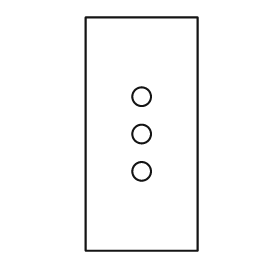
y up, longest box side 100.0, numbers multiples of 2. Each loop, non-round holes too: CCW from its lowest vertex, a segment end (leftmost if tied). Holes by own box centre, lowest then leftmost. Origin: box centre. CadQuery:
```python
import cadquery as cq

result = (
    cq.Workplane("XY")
    .moveTo(-24.0, -50.0)
    .lineTo(24.0, -50.0)
    .lineTo(24.0, 50.0)
    .lineTo(-24.0, 50.0)
    .close()
    .moveTo(0.0, -16.0)
    .circle(4.0)
    .moveTo(0.0, 0.0)
    .circle(4.0)
    .moveTo(0.0, 16.0)
    .circle(4.0)
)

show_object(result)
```